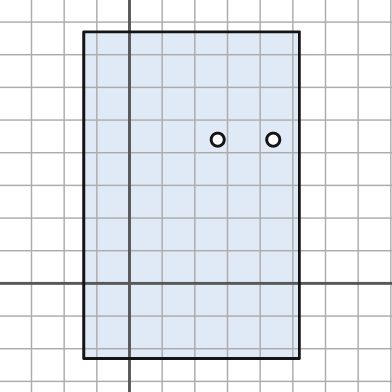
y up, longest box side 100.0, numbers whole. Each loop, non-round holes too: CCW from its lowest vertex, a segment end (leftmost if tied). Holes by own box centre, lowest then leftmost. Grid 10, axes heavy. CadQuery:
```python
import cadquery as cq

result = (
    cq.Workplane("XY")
    .moveTo(-14.0, -23.0)
    .lineTo(52.0, -23.0)
    .lineTo(52.0, 77.0)
    .lineTo(-14.0, 77.0)
    .close()
    .moveTo(27.0, 44.0)
    .circle(2.0)
    .moveTo(44.0, 44.0)
    .circle(2.0)
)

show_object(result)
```